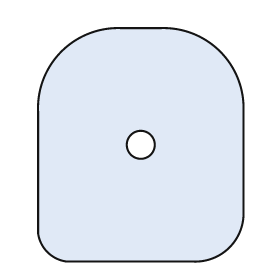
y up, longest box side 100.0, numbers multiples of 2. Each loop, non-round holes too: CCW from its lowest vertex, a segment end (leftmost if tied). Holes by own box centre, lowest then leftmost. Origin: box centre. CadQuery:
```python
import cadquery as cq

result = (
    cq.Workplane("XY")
    .moveTo(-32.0, -50.0)
    .lineTo(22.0, -50.0)
    .threePointArc((38.0, -44.0), (44.0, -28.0))
    .lineTo(44.0, 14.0)
    .threePointArc((34.0, 40.0), (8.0, 50.0))
    .lineTo(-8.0, 50.0)
    .threePointArc((-34.0, 40.0), (-44.0, 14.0))
    .lineTo(-44.0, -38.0)
    .threePointArc((-40.0, -46.0), (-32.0, -50.0))
    .close()
    .moveTo(0.0, 0.0)
    .circle(6.0)
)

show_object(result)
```